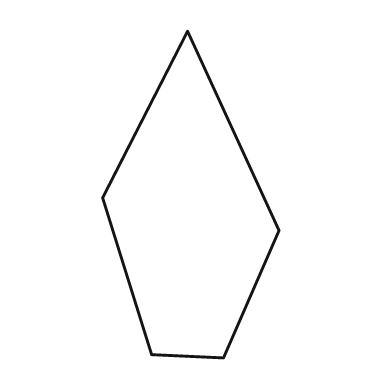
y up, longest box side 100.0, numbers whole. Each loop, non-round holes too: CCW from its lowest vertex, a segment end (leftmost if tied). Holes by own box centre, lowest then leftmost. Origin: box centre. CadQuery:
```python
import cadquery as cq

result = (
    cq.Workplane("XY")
    .moveTo(10.0, -50.0)
    .lineTo(27.0, -11.0)
    .lineTo(-1.0, 50.0)
    .lineTo(-27.0, -1.0)
    .lineTo(-12.0, -49.0)
    .close()
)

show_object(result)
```